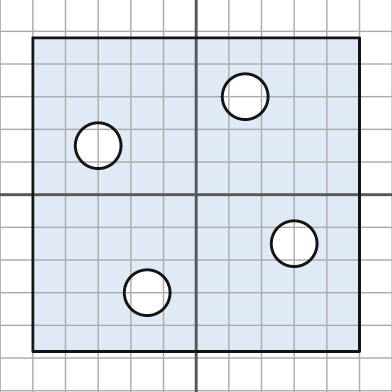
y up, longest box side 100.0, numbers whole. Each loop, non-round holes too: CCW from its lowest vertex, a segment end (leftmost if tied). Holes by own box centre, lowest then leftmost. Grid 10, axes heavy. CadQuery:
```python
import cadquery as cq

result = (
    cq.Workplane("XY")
    .moveTo(-50.0, -48.0)
    .lineTo(50.0, -48.0)
    .lineTo(50.0, 48.0)
    .lineTo(-50.0, 48.0)
    .close()
    .moveTo(-15.0, -30.0)
    .circle(7.0)
    .moveTo(30.0, -15.0)
    .circle(7.0)
    .moveTo(-30.0, 15.0)
    .circle(7.0)
    .moveTo(15.0, 30.0)
    .circle(7.0)
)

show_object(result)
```